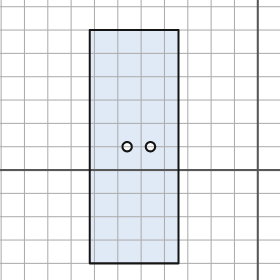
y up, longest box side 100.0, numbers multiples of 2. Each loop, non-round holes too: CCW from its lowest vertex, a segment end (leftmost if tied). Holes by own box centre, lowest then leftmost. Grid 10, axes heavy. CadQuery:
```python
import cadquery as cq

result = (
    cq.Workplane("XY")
    .moveTo(-72.0, -40.0)
    .lineTo(-34.0, -40.0)
    .lineTo(-34.0, 60.0)
    .lineTo(-72.0, 60.0)
    .close()
    .moveTo(-56.0, 10.0)
    .circle(2.0)
    .moveTo(-46.0, 10.0)
    .circle(2.0)
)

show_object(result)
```